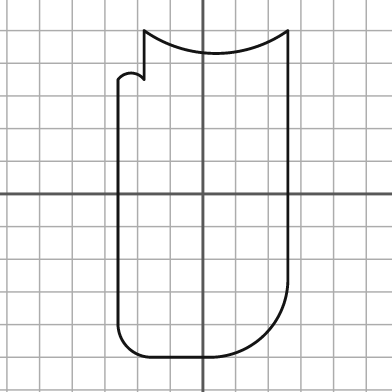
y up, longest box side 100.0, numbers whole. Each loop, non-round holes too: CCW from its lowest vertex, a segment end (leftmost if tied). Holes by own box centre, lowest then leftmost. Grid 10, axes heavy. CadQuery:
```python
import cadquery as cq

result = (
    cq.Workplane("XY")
    .moveTo(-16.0, -50.0)
    .lineTo(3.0, -50.0)
    .threePointArc((19.0, -43.0), (26.0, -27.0))
    .lineTo(26.0, 50.0)
    .threePointArc((4.0, 43.0), (-18.0, 50.0))
    .lineTo(-18.0, 35.0)
    .threePointArc((-22.0, 37.0), (-26.0, 35.0))
    .lineTo(-26.0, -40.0)
    .threePointArc((-23.0, -47.0), (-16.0, -50.0))
    .close()
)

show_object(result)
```